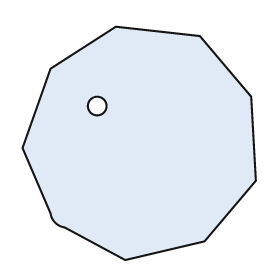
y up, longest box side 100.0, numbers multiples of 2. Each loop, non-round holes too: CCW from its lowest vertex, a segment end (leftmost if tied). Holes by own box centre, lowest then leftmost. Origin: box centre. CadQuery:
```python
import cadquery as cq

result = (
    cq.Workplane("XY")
    .moveTo(-6.0, -50.0)
    .lineTo(28.0, -42.0)
    .lineTo(50.0, -16.0)
    .lineTo(48.0, 20.0)
    .lineTo(26.0, 46.0)
    .lineTo(-10.0, 50.0)
    .lineTo(-38.0, 32.0)
    .lineTo(-50.0, -2.0)
    .lineTo(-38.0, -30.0)
    .threePointArc((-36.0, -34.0), (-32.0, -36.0))
    .close()
    .moveTo(-18.0, 16.0)
    .circle(4.0)
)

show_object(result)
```